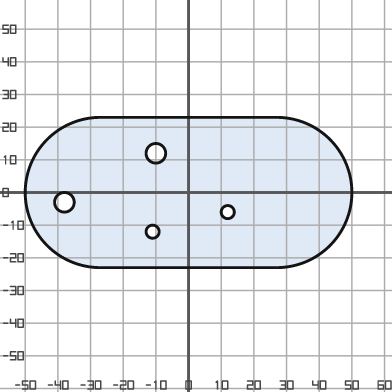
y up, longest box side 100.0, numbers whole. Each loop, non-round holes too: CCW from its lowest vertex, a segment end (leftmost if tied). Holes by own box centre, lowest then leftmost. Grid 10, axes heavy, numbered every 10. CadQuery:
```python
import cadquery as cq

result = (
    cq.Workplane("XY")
    .moveTo(-27.0, -23.0)
    .lineTo(27.0, -23.0)
    .threePointArc((50.0, 0.0), (27.0, 23.0))
    .lineTo(-27.0, 23.0)
    .threePointArc((-50.0, 0.0), (-27.0, -23.0))
    .close()
    .moveTo(-11.0, -12.0)
    .circle(2.0)
    .moveTo(12.0, -6.0)
    .circle(2.0)
    .moveTo(-38.0, -3.0)
    .circle(3.0)
    .moveTo(-10.0, 12.0)
    .circle(3.0)
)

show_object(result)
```